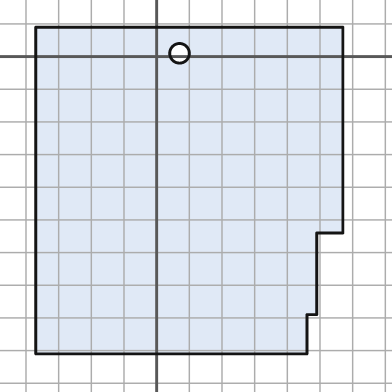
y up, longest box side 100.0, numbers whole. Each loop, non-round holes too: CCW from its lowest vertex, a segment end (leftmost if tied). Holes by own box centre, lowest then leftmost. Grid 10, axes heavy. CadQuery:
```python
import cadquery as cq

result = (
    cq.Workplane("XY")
    .moveTo(-37.0, -91.0)
    .lineTo(46.0, -91.0)
    .lineTo(46.0, -79.0)
    .lineTo(49.0, -79.0)
    .lineTo(49.0, -54.0)
    .lineTo(57.0, -54.0)
    .lineTo(57.0, 9.0)
    .lineTo(-37.0, 9.0)
    .close()
    .moveTo(7.0, 1.0)
    .circle(3.0)
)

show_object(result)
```